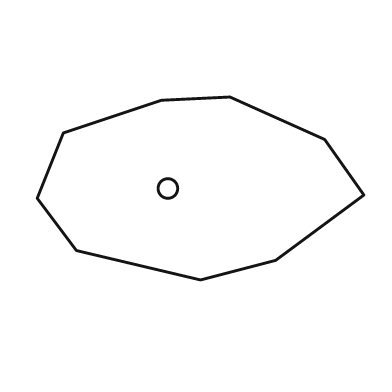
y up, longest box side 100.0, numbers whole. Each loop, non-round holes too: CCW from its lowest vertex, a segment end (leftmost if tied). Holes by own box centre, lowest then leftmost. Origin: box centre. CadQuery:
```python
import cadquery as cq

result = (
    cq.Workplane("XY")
    .moveTo(0.0, -28.0)
    .lineTo(23.0, -22.0)
    .lineTo(50.0, -2.0)
    .lineTo(38.0, 15.0)
    .lineTo(9.0, 28.0)
    .lineTo(-12.0, 27.0)
    .lineTo(-42.0, 17.0)
    .lineTo(-50.0, -3.0)
    .lineTo(-38.0, -19.0)
    .close()
    .moveTo(-10.0, 0.0)
    .circle(3.0)
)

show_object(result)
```